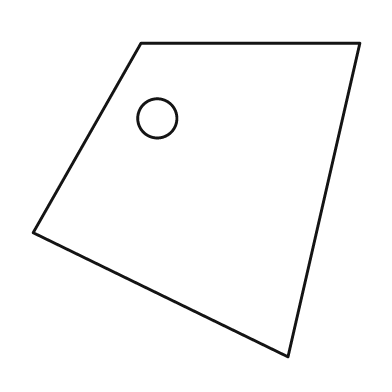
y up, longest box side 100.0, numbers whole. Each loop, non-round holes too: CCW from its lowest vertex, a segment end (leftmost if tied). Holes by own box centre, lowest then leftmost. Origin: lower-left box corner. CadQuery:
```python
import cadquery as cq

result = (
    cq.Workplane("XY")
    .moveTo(78.0, 0.0)
    .lineTo(100.0, 96.0)
    .lineTo(33.0, 96.0)
    .lineTo(0.0, 38.0)
    .close()
    .moveTo(38.0, 73.0)
    .circle(6.0)
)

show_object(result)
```